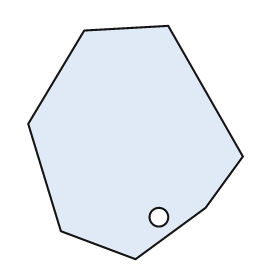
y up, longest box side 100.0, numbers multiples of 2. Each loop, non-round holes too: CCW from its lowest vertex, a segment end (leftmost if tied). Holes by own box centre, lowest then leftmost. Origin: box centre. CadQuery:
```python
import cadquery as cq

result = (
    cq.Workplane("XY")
    .moveTo(0.0, -50.0)
    .lineTo(30.0, -28.0)
    .lineTo(46.0, -6.0)
    .lineTo(14.0, 50.0)
    .lineTo(-22.0, 48.0)
    .lineTo(-46.0, 8.0)
    .lineTo(-32.0, -38.0)
    .close()
    .moveTo(10.0, -32.0)
    .circle(4.0)
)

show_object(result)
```